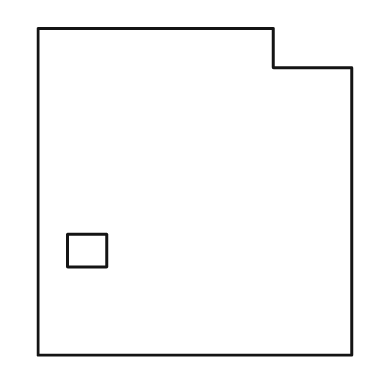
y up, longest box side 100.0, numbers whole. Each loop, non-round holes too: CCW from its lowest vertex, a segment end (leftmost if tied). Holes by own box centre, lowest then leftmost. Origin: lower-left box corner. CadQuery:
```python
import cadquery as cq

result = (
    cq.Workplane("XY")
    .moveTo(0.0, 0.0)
    .lineTo(96.0, 0.0)
    .lineTo(96.0, 88.0)
    .lineTo(72.0, 88.0)
    .lineTo(72.0, 100.0)
    .lineTo(0.0, 100.0)
    .close()
    .moveTo(9.0, 27.0)
    .lineTo(21.0, 27.0)
    .lineTo(21.0, 37.0)
    .lineTo(9.0, 37.0)
    .close()
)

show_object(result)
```